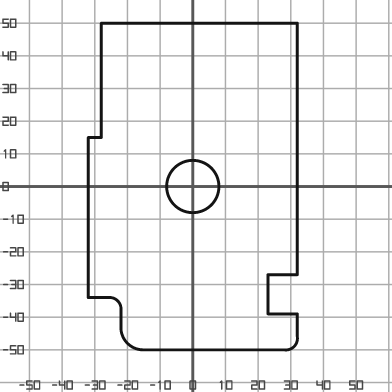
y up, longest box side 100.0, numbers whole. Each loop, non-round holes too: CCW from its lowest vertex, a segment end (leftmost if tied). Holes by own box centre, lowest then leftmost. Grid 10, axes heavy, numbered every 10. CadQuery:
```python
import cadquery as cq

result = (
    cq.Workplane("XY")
    .moveTo(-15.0, -50.0)
    .lineTo(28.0, -50.0)
    .threePointArc((31.0, -49.0), (32.0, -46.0))
    .lineTo(32.0, -39.0)
    .lineTo(23.0, -39.0)
    .lineTo(23.0, -27.0)
    .lineTo(32.0, -27.0)
    .lineTo(32.0, 50.0)
    .lineTo(-28.0, 50.0)
    .lineTo(-28.0, 15.0)
    .lineTo(-32.0, 15.0)
    .lineTo(-32.0, -34.0)
    .lineTo(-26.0, -34.0)
    .threePointArc((-23.0, -35.0), (-22.0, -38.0))
    .lineTo(-22.0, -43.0)
    .threePointArc((-20.0, -48.0), (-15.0, -50.0))
    .close()
    .moveTo(0.0, 0.0)
    .circle(8.0)
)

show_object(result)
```